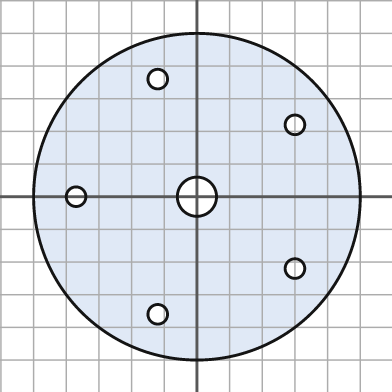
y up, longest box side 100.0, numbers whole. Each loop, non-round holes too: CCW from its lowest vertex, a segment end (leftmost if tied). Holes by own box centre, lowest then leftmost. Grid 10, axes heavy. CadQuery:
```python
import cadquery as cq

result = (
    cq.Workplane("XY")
    .moveTo(0.0, 0.0)
    .circle(50.0)
    .moveTo(-12.0, -36.0)
    .circle(3.0)
    .moveTo(30.0, -22.0)
    .circle(3.0)
    .moveTo(-37.0, 0.0)
    .circle(3.0)
    .moveTo(0.0, 0.0)
    .circle(6.0)
    .moveTo(30.0, 22.0)
    .circle(3.0)
    .moveTo(-12.0, 36.0)
    .circle(3.0)
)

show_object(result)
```